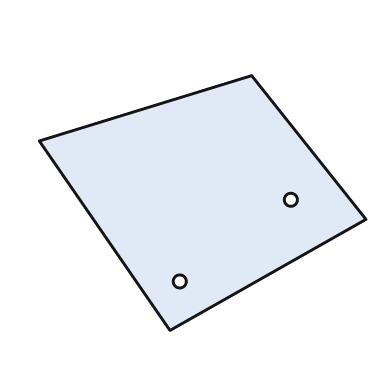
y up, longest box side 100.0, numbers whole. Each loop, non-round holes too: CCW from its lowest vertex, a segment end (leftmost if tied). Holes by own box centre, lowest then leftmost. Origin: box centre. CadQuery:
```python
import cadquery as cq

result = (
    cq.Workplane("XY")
    .moveTo(-10.0, -39.0)
    .lineTo(50.0, -5.0)
    .lineTo(15.0, 39.0)
    .lineTo(-50.0, 19.0)
    .close()
    .moveTo(-7.0, -24.0)
    .circle(2.0)
    .moveTo(27.0, 1.0)
    .circle(2.0)
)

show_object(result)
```